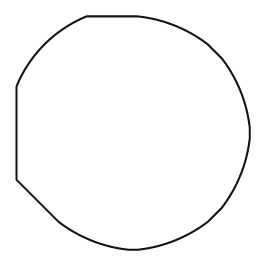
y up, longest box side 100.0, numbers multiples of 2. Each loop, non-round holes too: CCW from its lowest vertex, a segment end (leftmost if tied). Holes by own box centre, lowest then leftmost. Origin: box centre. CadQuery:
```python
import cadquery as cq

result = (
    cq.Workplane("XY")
    .moveTo(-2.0, -50.0)
    .lineTo(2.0, -50.0)
    .threePointArc((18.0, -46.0), (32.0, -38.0))
    .lineTo(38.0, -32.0)
    .threePointArc((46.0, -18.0), (50.0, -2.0))
    .lineTo(50.0, 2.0)
    .threePointArc((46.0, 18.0), (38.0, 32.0))
    .lineTo(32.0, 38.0)
    .threePointArc((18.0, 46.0), (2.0, 50.0))
    .lineTo(-20.0, 50.0)
    .threePointArc((-38.0, 38.0), (-50.0, 20.0))
    .lineTo(-50.0, -20.0)
    .lineTo(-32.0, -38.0)
    .threePointArc((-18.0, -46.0), (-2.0, -50.0))
    .close()
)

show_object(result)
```